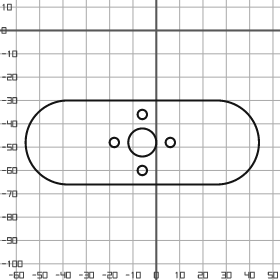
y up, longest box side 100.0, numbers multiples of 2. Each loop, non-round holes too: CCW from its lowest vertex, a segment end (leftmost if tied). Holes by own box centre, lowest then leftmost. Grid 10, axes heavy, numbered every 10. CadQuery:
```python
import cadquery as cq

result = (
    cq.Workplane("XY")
    .moveTo(-38.0, -66.0)
    .lineTo(26.0, -66.0)
    .threePointArc((44.0, -48.0), (26.0, -30.0))
    .lineTo(-38.0, -30.0)
    .threePointArc((-56.0, -48.0), (-38.0, -66.0))
    .close()
    .moveTo(-6.0, -60.0)
    .circle(2.0)
    .moveTo(-18.0, -48.0)
    .circle(2.0)
    .moveTo(-6.0, -48.0)
    .circle(6.0)
    .moveTo(6.0, -48.0)
    .circle(2.0)
    .moveTo(-6.0, -36.0)
    .circle(2.0)
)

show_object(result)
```